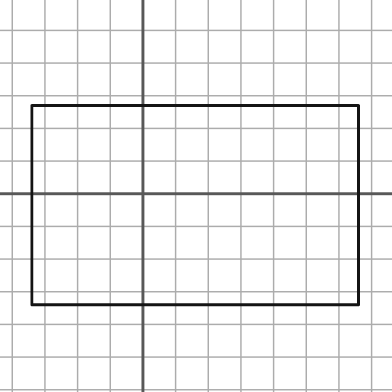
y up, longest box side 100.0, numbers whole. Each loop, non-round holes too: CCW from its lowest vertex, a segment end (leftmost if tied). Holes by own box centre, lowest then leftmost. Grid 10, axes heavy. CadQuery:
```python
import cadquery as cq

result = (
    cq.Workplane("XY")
    .moveTo(-34.0, -34.0)
    .lineTo(66.0, -34.0)
    .lineTo(66.0, 27.0)
    .lineTo(-34.0, 27.0)
    .close()
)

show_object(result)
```